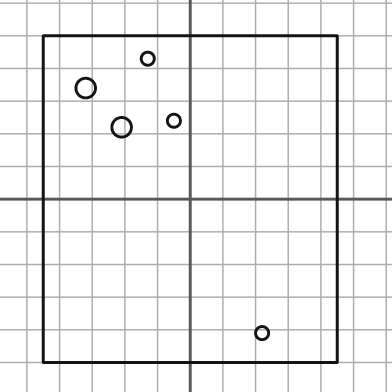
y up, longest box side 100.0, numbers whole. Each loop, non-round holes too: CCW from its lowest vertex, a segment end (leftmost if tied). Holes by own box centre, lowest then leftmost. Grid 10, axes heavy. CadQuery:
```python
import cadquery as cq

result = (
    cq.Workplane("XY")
    .moveTo(-45.0, -50.0)
    .lineTo(45.0, -50.0)
    .lineTo(45.0, 50.0)
    .lineTo(-45.0, 50.0)
    .close()
    .moveTo(22.0, -41.0)
    .circle(2.0)
    .moveTo(-21.0, 22.0)
    .circle(3.0)
    .moveTo(-5.0, 24.0)
    .circle(2.0)
    .moveTo(-32.0, 34.0)
    .circle(3.0)
    .moveTo(-13.0, 43.0)
    .circle(2.0)
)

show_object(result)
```